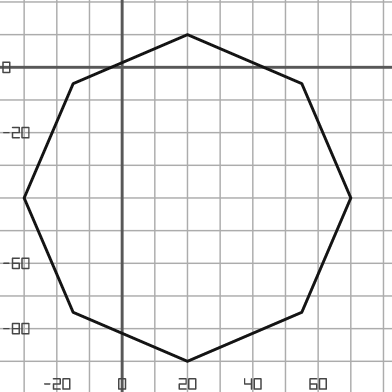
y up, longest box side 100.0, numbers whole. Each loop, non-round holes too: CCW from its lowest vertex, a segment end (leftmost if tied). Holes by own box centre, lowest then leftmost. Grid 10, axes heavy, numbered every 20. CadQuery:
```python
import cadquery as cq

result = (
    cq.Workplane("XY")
    .moveTo(20.0, -90.0)
    .lineTo(55.0, -75.0)
    .lineTo(70.0, -40.0)
    .lineTo(55.0, -5.0)
    .lineTo(20.0, 10.0)
    .lineTo(-15.0, -5.0)
    .lineTo(-30.0, -40.0)
    .lineTo(-15.0, -75.0)
    .close()
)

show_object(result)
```